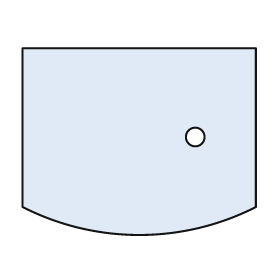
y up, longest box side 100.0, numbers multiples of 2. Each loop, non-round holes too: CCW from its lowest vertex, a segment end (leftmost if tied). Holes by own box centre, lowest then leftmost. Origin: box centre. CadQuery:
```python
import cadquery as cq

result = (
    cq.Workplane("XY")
    .moveTo(-50.0, -28.0)
    .threePointArc((0.0, -40.0), (50.0, -28.0))
    .lineTo(50.0, 40.0)
    .lineTo(-50.0, 40.0)
    .close()
    .moveTo(24.0, 2.0)
    .circle(4.0)
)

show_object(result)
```